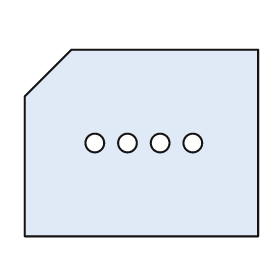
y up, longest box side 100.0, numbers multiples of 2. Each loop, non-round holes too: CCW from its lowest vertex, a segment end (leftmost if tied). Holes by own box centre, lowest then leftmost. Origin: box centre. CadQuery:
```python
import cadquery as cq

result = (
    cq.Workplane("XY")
    .moveTo(-50.0, -40.0)
    .lineTo(50.0, -40.0)
    .lineTo(50.0, 40.0)
    .lineTo(-30.0, 40.0)
    .lineTo(-50.0, 20.0)
    .close()
    .moveTo(-20.0, 0.0)
    .circle(4.0)
    .moveTo(-6.0, 0.0)
    .circle(4.0)
    .moveTo(8.0, 0.0)
    .circle(4.0)
    .moveTo(22.0, 0.0)
    .circle(4.0)
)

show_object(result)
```